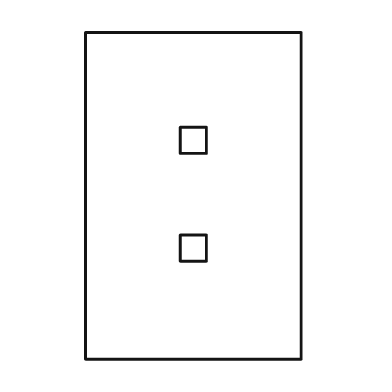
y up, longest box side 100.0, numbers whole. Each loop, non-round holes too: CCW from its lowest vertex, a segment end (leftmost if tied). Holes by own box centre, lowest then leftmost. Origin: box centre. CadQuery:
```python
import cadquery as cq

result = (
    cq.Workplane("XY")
    .moveTo(-33.0, -50.0)
    .lineTo(33.0, -50.0)
    .lineTo(33.0, 50.0)
    .lineTo(-33.0, 50.0)
    .close()
    .moveTo(-4.0, -20.0)
    .lineTo(4.0, -20.0)
    .lineTo(4.0, -12.0)
    .lineTo(-4.0, -12.0)
    .close()
    .moveTo(-4.0, 13.0)
    .lineTo(4.0, 13.0)
    .lineTo(4.0, 21.0)
    .lineTo(-4.0, 21.0)
    .close()
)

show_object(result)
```